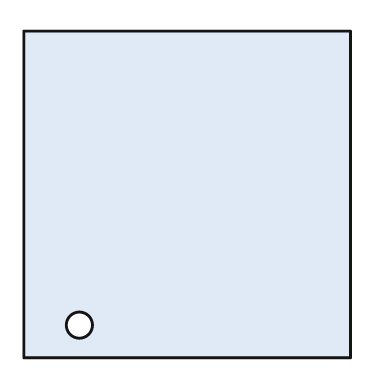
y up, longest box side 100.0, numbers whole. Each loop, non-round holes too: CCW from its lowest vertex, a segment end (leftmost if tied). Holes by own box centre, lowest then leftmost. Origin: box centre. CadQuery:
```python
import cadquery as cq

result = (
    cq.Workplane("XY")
    .moveTo(-50.0, -50.0)
    .lineTo(50.0, -50.0)
    .lineTo(50.0, 50.0)
    .lineTo(-50.0, 50.0)
    .close()
    .moveTo(-33.0, -40.0)
    .circle(4.0)
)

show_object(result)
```